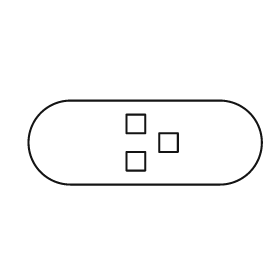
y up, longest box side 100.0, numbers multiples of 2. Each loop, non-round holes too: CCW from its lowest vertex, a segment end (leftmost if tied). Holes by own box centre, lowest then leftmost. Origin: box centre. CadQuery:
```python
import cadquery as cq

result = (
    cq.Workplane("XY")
    .moveTo(-32.0, -18.0)
    .lineTo(32.0, -18.0)
    .threePointArc((50.0, 0.0), (32.0, 18.0))
    .lineTo(-32.0, 18.0)
    .threePointArc((-50.0, 0.0), (-32.0, -18.0))
    .close()
    .moveTo(-8.0, -12.0)
    .lineTo(0.0, -12.0)
    .lineTo(0.0, -4.0)
    .lineTo(-8.0, -4.0)
    .close()
    .moveTo(6.0, -4.0)
    .lineTo(14.0, -4.0)
    .lineTo(14.0, 4.0)
    .lineTo(6.0, 4.0)
    .close()
    .moveTo(-8.0, 4.0)
    .lineTo(0.0, 4.0)
    .lineTo(0.0, 12.0)
    .lineTo(-8.0, 12.0)
    .close()
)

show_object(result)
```